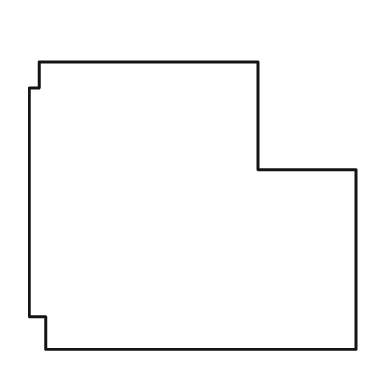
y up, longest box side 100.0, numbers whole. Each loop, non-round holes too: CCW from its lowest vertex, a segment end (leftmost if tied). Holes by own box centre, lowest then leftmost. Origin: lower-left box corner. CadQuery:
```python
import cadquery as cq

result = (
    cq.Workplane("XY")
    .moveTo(5.0, 0.0)
    .lineTo(100.0, 0.0)
    .lineTo(100.0, 55.0)
    .lineTo(70.0, 55.0)
    .lineTo(70.0, 88.0)
    .lineTo(3.0, 88.0)
    .lineTo(3.0, 80.0)
    .lineTo(0.0, 80.0)
    .lineTo(0.0, 10.0)
    .lineTo(5.0, 10.0)
    .close()
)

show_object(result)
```